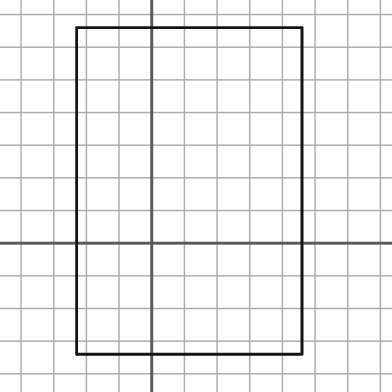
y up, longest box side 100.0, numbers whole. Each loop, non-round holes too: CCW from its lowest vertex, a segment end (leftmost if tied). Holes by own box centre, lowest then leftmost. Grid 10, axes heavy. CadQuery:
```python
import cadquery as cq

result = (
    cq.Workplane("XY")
    .moveTo(-23.0, -34.0)
    .lineTo(46.0, -34.0)
    .lineTo(46.0, 66.0)
    .lineTo(-23.0, 66.0)
    .close()
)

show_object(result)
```